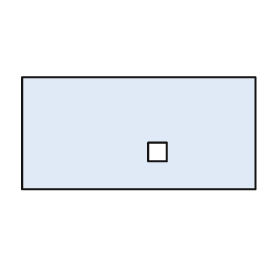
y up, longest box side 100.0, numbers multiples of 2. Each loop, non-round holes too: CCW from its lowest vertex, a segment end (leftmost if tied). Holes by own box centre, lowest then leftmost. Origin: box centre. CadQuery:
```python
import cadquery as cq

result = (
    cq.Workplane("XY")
    .moveTo(-50.0, -24.0)
    .lineTo(50.0, -24.0)
    .lineTo(50.0, 24.0)
    .lineTo(-50.0, 24.0)
    .close()
    .moveTo(4.0, -12.0)
    .lineTo(12.0, -12.0)
    .lineTo(12.0, -4.0)
    .lineTo(4.0, -4.0)
    .close()
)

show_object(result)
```